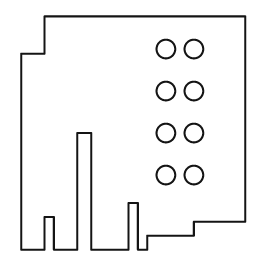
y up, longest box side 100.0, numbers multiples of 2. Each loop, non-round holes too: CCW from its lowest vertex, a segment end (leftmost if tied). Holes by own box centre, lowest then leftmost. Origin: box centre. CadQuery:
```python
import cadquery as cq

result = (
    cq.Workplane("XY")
    .moveTo(-48.0, -50.0)
    .lineTo(-38.0, -50.0)
    .lineTo(-38.0, -36.0)
    .lineTo(-34.0, -36.0)
    .lineTo(-34.0, -50.0)
    .lineTo(-24.0, -50.0)
    .lineTo(-24.0, 0.0)
    .lineTo(-18.0, 0.0)
    .lineTo(-18.0, -50.0)
    .lineTo(-2.0, -50.0)
    .lineTo(-2.0, -30.0)
    .lineTo(2.0, -30.0)
    .lineTo(2.0, -50.0)
    .lineTo(6.0, -50.0)
    .lineTo(6.0, -44.0)
    .lineTo(26.0, -44.0)
    .lineTo(26.0, -38.0)
    .lineTo(48.0, -38.0)
    .lineTo(48.0, 50.0)
    .lineTo(-38.0, 50.0)
    .lineTo(-38.0, 34.0)
    .lineTo(-48.0, 34.0)
    .close()
    .moveTo(14.0, -18.0)
    .circle(4.0)
    .moveTo(26.0, -18.0)
    .circle(4.0)
    .moveTo(14.0, 0.0)
    .circle(4.0)
    .moveTo(26.0, 0.0)
    .circle(4.0)
    .moveTo(14.0, 18.0)
    .circle(4.0)
    .moveTo(26.0, 18.0)
    .circle(4.0)
    .moveTo(14.0, 36.0)
    .circle(4.0)
    .moveTo(26.0, 36.0)
    .circle(4.0)
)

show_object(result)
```